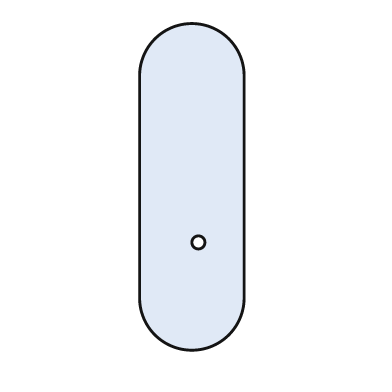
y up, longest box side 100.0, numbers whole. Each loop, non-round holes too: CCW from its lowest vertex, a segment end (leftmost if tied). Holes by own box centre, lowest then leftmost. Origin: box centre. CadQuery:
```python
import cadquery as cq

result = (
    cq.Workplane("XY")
    .moveTo(-16.0, -34.0)
    .threePointArc((0.0, -50.0), (16.0, -34.0))
    .lineTo(16.0, 34.0)
    .threePointArc((0.0, 50.0), (-16.0, 34.0))
    .close()
    .moveTo(2.0, -17.0)
    .circle(2.0)
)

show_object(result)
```